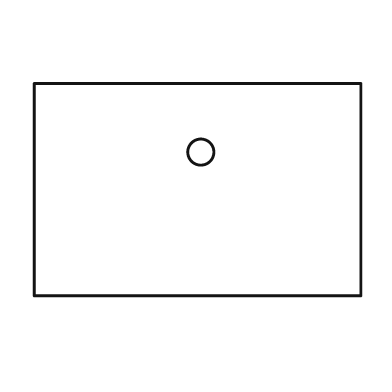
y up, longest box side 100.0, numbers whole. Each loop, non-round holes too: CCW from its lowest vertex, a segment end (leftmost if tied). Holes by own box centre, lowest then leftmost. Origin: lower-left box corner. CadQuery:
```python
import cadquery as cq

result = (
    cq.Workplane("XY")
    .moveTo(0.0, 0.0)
    .lineTo(100.0, 0.0)
    .lineTo(100.0, 65.0)
    .lineTo(0.0, 65.0)
    .close()
    .moveTo(51.0, 44.0)
    .circle(4.0)
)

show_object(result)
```